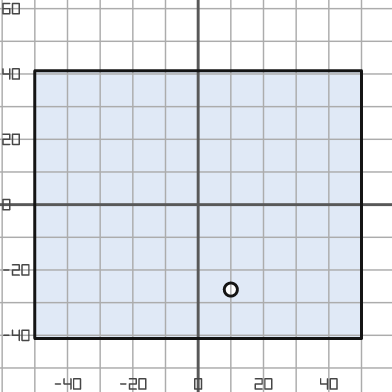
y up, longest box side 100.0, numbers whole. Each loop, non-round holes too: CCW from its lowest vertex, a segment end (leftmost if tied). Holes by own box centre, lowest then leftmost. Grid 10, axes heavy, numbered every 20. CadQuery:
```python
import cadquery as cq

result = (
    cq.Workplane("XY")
    .moveTo(-50.0, -41.0)
    .lineTo(50.0, -41.0)
    .lineTo(50.0, 41.0)
    .lineTo(-50.0, 41.0)
    .close()
    .moveTo(10.0, -26.0)
    .circle(2.0)
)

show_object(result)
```